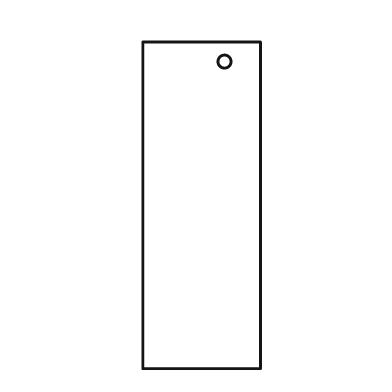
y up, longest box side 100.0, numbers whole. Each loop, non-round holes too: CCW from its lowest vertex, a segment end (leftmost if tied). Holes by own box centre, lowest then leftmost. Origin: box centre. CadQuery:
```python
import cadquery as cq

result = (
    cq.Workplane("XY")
    .moveTo(-18.0, -50.0)
    .lineTo(18.0, -50.0)
    .lineTo(18.0, 50.0)
    .lineTo(-18.0, 50.0)
    .close()
    .moveTo(7.0, 44.0)
    .circle(2.0)
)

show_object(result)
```